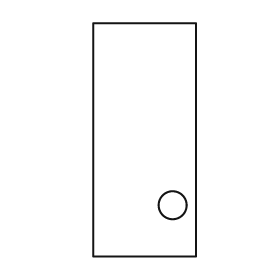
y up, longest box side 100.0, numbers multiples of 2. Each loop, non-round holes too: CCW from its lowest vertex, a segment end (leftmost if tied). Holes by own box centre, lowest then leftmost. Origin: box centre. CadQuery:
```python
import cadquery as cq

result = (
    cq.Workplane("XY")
    .moveTo(-22.0, -50.0)
    .lineTo(22.0, -50.0)
    .lineTo(22.0, 50.0)
    .lineTo(-22.0, 50.0)
    .close()
    .moveTo(12.0, -28.0)
    .circle(6.0)
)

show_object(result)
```